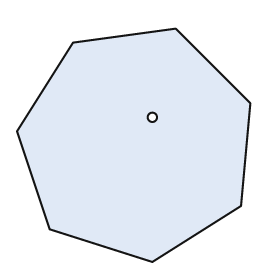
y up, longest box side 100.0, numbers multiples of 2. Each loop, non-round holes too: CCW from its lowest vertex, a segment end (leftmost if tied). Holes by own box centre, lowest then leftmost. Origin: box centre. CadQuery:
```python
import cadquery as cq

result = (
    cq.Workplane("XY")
    .moveTo(8.0, -50.0)
    .lineTo(46.0, -26.0)
    .lineTo(50.0, 18.0)
    .lineTo(18.0, 50.0)
    .lineTo(-26.0, 44.0)
    .lineTo(-50.0, 6.0)
    .lineTo(-36.0, -36.0)
    .close()
    .moveTo(8.0, 12.0)
    .circle(2.0)
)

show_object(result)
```